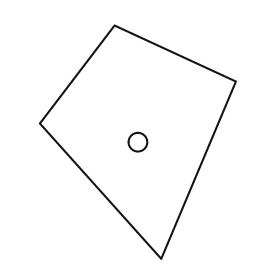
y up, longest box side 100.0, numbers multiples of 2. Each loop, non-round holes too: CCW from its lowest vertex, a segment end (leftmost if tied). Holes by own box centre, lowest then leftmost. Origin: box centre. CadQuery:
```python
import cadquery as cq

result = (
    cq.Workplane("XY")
    .moveTo(10.0, -50.0)
    .lineTo(42.0, 26.0)
    .lineTo(-10.0, 50.0)
    .lineTo(-42.0, 8.0)
    .close()
    .moveTo(0.0, 0.0)
    .circle(4.0)
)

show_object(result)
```